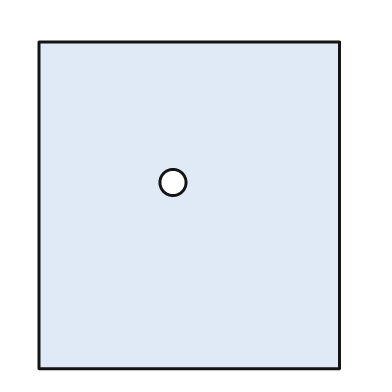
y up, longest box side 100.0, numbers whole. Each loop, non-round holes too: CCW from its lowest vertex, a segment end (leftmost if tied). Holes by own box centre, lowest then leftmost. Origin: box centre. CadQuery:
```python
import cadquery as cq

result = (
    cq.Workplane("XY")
    .moveTo(-46.0, -50.0)
    .lineTo(46.0, -50.0)
    .lineTo(46.0, 50.0)
    .lineTo(-46.0, 50.0)
    .close()
    .moveTo(-5.0, 7.0)
    .circle(4.0)
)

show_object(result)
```